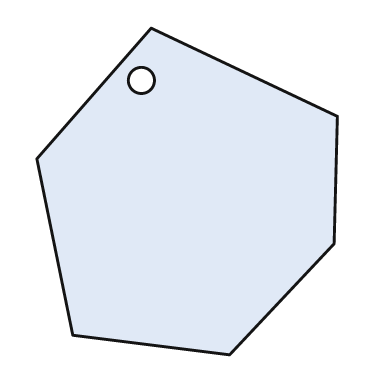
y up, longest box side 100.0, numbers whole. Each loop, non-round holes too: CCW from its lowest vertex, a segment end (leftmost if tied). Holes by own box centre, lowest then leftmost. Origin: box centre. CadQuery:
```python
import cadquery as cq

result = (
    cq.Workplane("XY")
    .moveTo(13.0, -50.0)
    .lineTo(45.0, -16.0)
    .lineTo(46.0, 23.0)
    .lineTo(-11.0, 50.0)
    .lineTo(-46.0, 10.0)
    .lineTo(-35.0, -44.0)
    .close()
    .moveTo(-14.0, 34.0)
    .circle(4.0)
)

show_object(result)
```